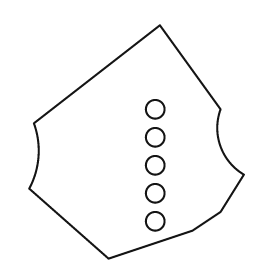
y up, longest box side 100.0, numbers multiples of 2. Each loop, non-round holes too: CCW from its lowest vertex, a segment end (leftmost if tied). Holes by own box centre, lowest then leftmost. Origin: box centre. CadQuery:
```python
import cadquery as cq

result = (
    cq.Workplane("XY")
    .moveTo(-12.0, -50.0)
    .lineTo(24.0, -38.0)
    .lineTo(36.0, -30.0)
    .lineTo(46.0, -14.0)
    .threePointArc((36.0, -2.0), (36.0, 14.0))
    .lineTo(10.0, 50.0)
    .lineTo(-44.0, 8.0)
    .threePointArc((-42.0, -6.0), (-46.0, -20.0))
    .close()
    .moveTo(8.0, -34.0)
    .circle(4.0)
    .moveTo(8.0, -22.0)
    .circle(4.0)
    .moveTo(8.0, -10.0)
    .circle(4.0)
    .moveTo(8.0, 2.0)
    .circle(4.0)
    .moveTo(8.0, 14.0)
    .circle(4.0)
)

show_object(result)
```